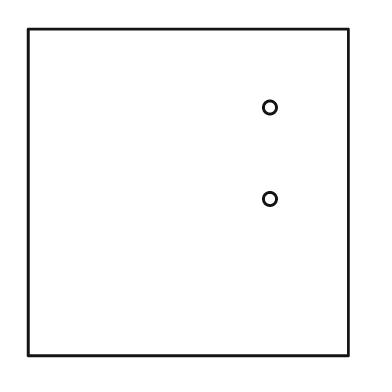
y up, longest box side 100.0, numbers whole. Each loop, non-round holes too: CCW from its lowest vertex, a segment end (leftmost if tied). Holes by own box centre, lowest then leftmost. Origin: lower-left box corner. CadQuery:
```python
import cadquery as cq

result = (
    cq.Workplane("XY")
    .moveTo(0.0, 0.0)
    .lineTo(98.0, 0.0)
    .lineTo(98.0, 100.0)
    .lineTo(0.0, 100.0)
    .close()
    .moveTo(74.0, 48.0)
    .circle(2.0)
    .moveTo(74.0, 76.0)
    .circle(2.0)
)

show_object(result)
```